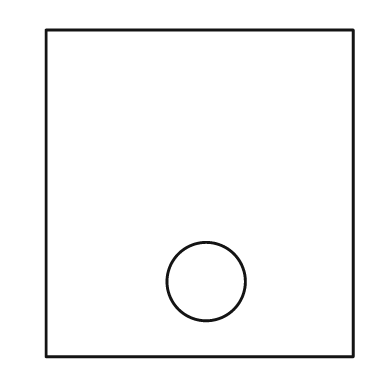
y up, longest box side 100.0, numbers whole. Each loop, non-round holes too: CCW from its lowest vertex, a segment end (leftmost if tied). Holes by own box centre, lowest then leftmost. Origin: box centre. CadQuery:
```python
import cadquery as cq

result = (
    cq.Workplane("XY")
    .moveTo(-47.0, -50.0)
    .lineTo(47.0, -50.0)
    .lineTo(47.0, 50.0)
    .lineTo(-47.0, 50.0)
    .close()
    .moveTo(2.0, -27.0)
    .circle(12.0)
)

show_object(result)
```